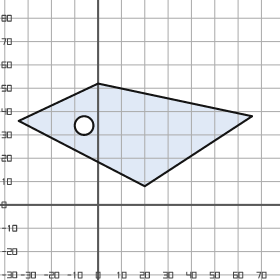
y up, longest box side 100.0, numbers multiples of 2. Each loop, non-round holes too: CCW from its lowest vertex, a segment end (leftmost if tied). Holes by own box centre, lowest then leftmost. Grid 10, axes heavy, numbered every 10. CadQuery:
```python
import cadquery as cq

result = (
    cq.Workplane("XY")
    .moveTo(20.0, 8.0)
    .lineTo(66.0, 38.0)
    .lineTo(0.0, 52.0)
    .lineTo(-34.0, 36.0)
    .close()
    .moveTo(-6.0, 34.0)
    .circle(4.0)
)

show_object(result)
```